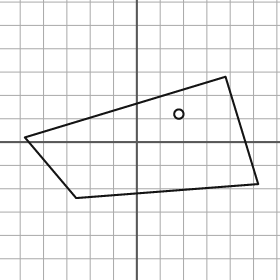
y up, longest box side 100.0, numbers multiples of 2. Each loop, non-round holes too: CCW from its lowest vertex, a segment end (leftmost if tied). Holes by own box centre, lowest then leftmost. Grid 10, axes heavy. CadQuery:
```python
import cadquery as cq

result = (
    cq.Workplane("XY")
    .moveTo(-26.0, -24.0)
    .lineTo(52.0, -18.0)
    .lineTo(38.0, 28.0)
    .lineTo(-48.0, 2.0)
    .close()
    .moveTo(18.0, 12.0)
    .circle(2.0)
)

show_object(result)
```